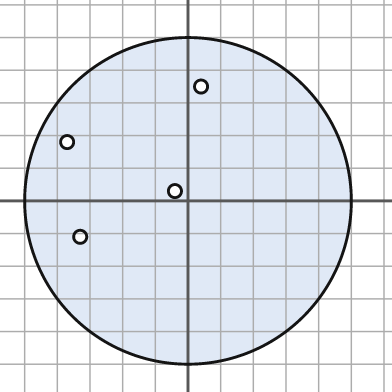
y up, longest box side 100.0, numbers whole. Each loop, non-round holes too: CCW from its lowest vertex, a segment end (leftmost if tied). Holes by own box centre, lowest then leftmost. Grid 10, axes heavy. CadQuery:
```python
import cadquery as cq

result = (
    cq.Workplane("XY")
    .moveTo(0.0, 0.0)
    .circle(50.0)
    .moveTo(-33.0, -11.0)
    .circle(2.0)
    .moveTo(-4.0, 3.0)
    .circle(2.0)
    .moveTo(-37.0, 18.0)
    .circle(2.0)
    .moveTo(4.0, 35.0)
    .circle(2.0)
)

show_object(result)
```